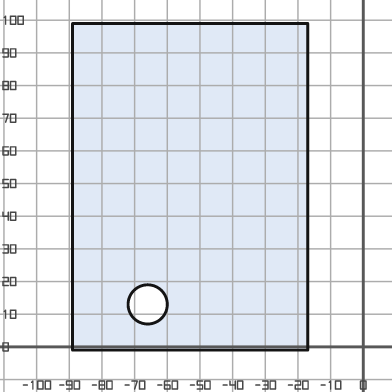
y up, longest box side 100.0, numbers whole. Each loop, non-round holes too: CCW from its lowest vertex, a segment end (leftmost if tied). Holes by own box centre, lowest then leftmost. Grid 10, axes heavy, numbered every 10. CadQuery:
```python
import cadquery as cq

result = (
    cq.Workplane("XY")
    .moveTo(-89.0, -1.0)
    .lineTo(-17.0, -1.0)
    .lineTo(-17.0, 99.0)
    .lineTo(-89.0, 99.0)
    .close()
    .moveTo(-66.0, 13.0)
    .circle(6.0)
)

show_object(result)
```